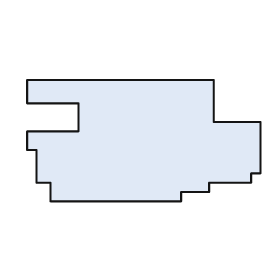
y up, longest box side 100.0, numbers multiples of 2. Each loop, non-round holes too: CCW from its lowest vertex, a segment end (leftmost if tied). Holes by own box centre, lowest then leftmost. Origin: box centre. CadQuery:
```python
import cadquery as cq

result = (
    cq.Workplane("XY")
    .moveTo(-40.0, -26.0)
    .lineTo(16.0, -26.0)
    .lineTo(16.0, -22.0)
    .lineTo(28.0, -22.0)
    .lineTo(28.0, -18.0)
    .lineTo(46.0, -18.0)
    .lineTo(46.0, -14.0)
    .lineTo(50.0, -14.0)
    .lineTo(50.0, 8.0)
    .lineTo(30.0, 8.0)
    .lineTo(30.0, 26.0)
    .lineTo(-50.0, 26.0)
    .lineTo(-50.0, 16.0)
    .lineTo(-28.0, 16.0)
    .lineTo(-28.0, 4.0)
    .lineTo(-50.0, 4.0)
    .lineTo(-50.0, -4.0)
    .lineTo(-46.0, -4.0)
    .lineTo(-46.0, -18.0)
    .lineTo(-40.0, -18.0)
    .close()
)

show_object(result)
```